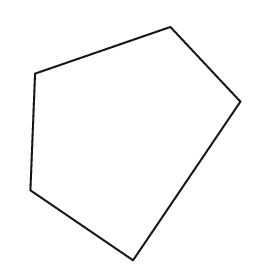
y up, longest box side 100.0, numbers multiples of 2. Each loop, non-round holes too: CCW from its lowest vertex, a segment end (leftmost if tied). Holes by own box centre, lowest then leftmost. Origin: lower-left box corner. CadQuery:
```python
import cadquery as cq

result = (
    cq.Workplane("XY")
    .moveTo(44.0, 0.0)
    .lineTo(90.0, 68.0)
    .lineTo(60.0, 100.0)
    .lineTo(2.0, 80.0)
    .lineTo(0.0, 30.0)
    .close()
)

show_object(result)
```